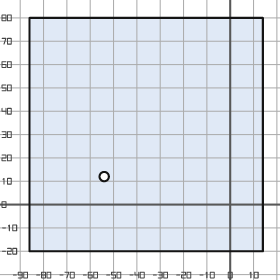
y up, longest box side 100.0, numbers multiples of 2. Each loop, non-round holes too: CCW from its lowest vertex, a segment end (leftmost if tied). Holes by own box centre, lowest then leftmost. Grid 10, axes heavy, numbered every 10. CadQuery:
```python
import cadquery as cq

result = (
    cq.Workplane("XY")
    .moveTo(-86.0, -20.0)
    .lineTo(14.0, -20.0)
    .lineTo(14.0, 80.0)
    .lineTo(-86.0, 80.0)
    .close()
    .moveTo(-54.0, 12.0)
    .circle(2.0)
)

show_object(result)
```